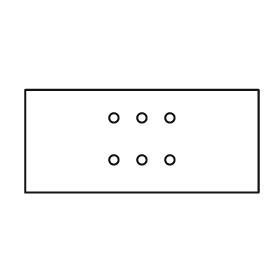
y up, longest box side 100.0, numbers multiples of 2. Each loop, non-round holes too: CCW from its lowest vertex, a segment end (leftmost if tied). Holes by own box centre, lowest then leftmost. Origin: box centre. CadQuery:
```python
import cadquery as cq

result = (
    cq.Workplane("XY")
    .moveTo(-50.0, -22.0)
    .lineTo(50.0, -22.0)
    .lineTo(50.0, 22.0)
    .lineTo(-50.0, 22.0)
    .close()
    .moveTo(-12.0, -8.0)
    .circle(2.0)
    .moveTo(0.0, -8.0)
    .circle(2.0)
    .moveTo(12.0, -8.0)
    .circle(2.0)
    .moveTo(-12.0, 10.0)
    .circle(2.0)
    .moveTo(0.0, 10.0)
    .circle(2.0)
    .moveTo(12.0, 10.0)
    .circle(2.0)
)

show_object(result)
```